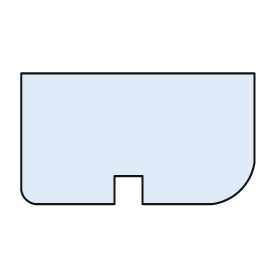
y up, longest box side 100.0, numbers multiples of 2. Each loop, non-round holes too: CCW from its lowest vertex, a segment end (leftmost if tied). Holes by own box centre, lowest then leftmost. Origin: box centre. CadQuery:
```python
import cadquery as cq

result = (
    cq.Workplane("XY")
    .moveTo(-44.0, -28.0)
    .lineTo(-10.0, -28.0)
    .lineTo(-10.0, -16.0)
    .lineTo(2.0, -16.0)
    .lineTo(2.0, -28.0)
    .lineTo(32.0, -28.0)
    .threePointArc((44.0, -22.0), (50.0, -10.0))
    .lineTo(50.0, 28.0)
    .lineTo(-50.0, 28.0)
    .lineTo(-50.0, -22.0)
    .threePointArc((-48.0, -26.0), (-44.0, -28.0))
    .close()
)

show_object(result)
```